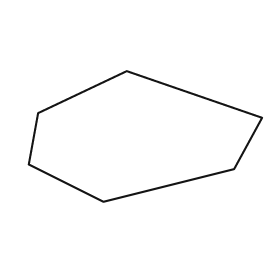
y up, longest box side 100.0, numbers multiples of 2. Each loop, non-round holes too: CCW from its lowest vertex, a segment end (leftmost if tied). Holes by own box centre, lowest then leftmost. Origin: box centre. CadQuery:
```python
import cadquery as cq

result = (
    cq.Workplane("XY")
    .moveTo(-18.0, -28.0)
    .lineTo(38.0, -14.0)
    .lineTo(50.0, 8.0)
    .lineTo(-8.0, 28.0)
    .lineTo(-46.0, 10.0)
    .lineTo(-50.0, -12.0)
    .close()
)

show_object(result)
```